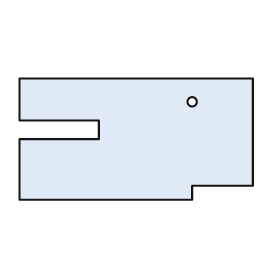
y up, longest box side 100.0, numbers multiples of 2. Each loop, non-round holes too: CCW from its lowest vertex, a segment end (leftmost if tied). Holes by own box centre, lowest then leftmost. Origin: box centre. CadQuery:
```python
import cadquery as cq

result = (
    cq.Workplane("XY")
    .moveTo(-50.0, -26.0)
    .lineTo(24.0, -26.0)
    .lineTo(24.0, -20.0)
    .lineTo(50.0, -20.0)
    .lineTo(50.0, 26.0)
    .lineTo(-50.0, 26.0)
    .lineTo(-50.0, 8.0)
    .lineTo(-16.0, 8.0)
    .lineTo(-16.0, 0.0)
    .lineTo(-50.0, 0.0)
    .close()
    .moveTo(24.0, 16.0)
    .circle(2.0)
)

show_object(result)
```